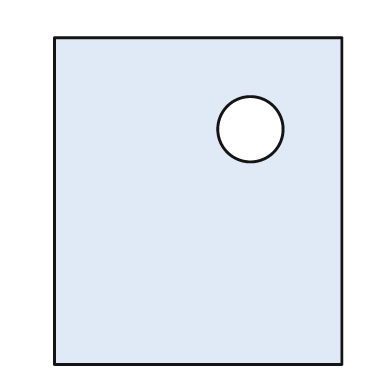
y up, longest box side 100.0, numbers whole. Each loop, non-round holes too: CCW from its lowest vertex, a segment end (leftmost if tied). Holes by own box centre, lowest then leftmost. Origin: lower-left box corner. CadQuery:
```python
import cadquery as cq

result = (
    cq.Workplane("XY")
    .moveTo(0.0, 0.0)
    .lineTo(88.0, 0.0)
    .lineTo(88.0, 100.0)
    .lineTo(0.0, 100.0)
    .close()
    .moveTo(60.0, 72.0)
    .circle(10.0)
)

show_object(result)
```